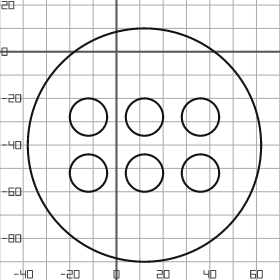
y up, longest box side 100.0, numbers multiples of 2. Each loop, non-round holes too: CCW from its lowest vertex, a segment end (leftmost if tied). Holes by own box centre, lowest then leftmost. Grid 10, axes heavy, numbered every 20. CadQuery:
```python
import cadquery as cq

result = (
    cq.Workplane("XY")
    .moveTo(12.0, -40.0)
    .circle(50.0)
    .moveTo(-12.0, -52.0)
    .circle(8.0)
    .moveTo(12.0, -52.0)
    .circle(8.0)
    .moveTo(36.0, -52.0)
    .circle(8.0)
    .moveTo(-12.0, -28.0)
    .circle(8.0)
    .moveTo(12.0, -28.0)
    .circle(8.0)
    .moveTo(36.0, -28.0)
    .circle(8.0)
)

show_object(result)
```